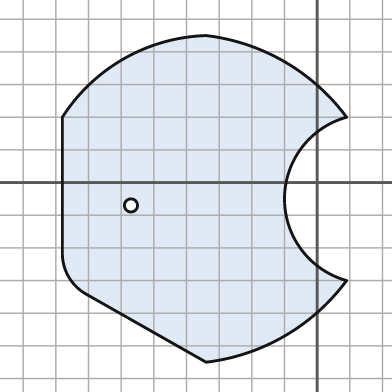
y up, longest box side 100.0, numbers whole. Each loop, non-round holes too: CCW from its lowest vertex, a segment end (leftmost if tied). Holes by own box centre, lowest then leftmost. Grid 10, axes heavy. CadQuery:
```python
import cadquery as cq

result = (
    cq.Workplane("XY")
    .moveTo(-34.0, -55.0)
    .threePointArc((-10.0, -47.0), (9.0, -30.0))
    .threePointArc((-10.0, -5.0), (9.0, 20.0))
    .threePointArc((-10.0, 37.0), (-34.0, 45.0))
    .threePointArc((-59.0, 38.0), (-78.0, 20.0))
    .lineTo(-78.0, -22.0)
    .threePointArc((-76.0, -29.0), (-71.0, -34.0))
    .close()
    .moveTo(-57.0, -7.0)
    .circle(2.0)
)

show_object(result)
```